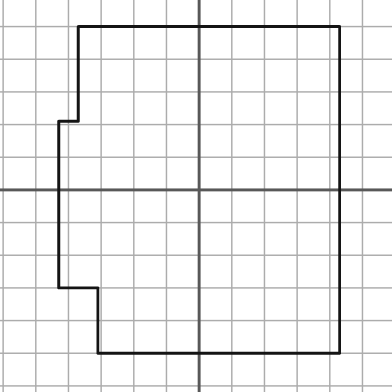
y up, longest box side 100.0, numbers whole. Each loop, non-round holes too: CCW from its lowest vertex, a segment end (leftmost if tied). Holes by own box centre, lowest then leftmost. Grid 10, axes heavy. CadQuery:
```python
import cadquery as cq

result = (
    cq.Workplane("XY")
    .moveTo(-31.0, -50.0)
    .lineTo(43.0, -50.0)
    .lineTo(43.0, 50.0)
    .lineTo(-37.0, 50.0)
    .lineTo(-37.0, 21.0)
    .lineTo(-43.0, 21.0)
    .lineTo(-43.0, -30.0)
    .lineTo(-31.0, -30.0)
    .close()
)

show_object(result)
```